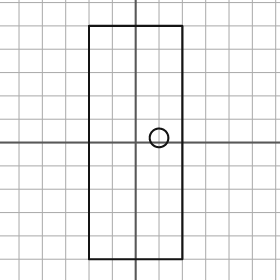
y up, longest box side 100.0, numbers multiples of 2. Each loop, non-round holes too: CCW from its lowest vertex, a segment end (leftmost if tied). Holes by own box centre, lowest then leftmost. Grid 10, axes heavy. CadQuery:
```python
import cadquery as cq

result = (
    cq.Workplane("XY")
    .moveTo(-20.0, -50.0)
    .lineTo(20.0, -50.0)
    .lineTo(20.0, 50.0)
    .lineTo(-20.0, 50.0)
    .close()
    .moveTo(10.0, 2.0)
    .circle(4.0)
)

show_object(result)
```